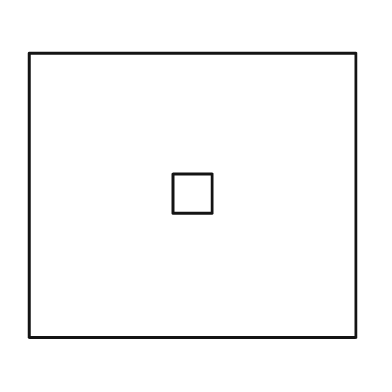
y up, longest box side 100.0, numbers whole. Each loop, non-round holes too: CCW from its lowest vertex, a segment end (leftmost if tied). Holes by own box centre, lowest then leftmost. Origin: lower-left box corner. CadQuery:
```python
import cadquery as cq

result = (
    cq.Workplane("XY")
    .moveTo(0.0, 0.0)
    .lineTo(100.0, 0.0)
    .lineTo(100.0, 87.0)
    .lineTo(0.0, 87.0)
    .close()
    .moveTo(44.0, 38.0)
    .lineTo(56.0, 38.0)
    .lineTo(56.0, 50.0)
    .lineTo(44.0, 50.0)
    .close()
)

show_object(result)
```